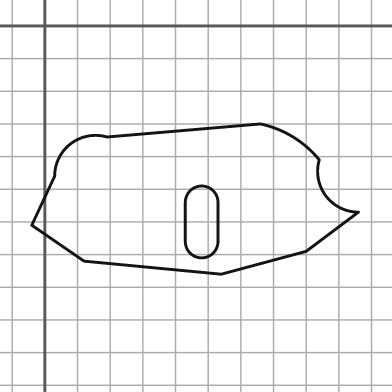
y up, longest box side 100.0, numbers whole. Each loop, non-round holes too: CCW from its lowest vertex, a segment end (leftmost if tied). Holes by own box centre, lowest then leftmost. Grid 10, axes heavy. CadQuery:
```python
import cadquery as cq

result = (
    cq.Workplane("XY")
    .moveTo(54.0, -76.0)
    .lineTo(80.0, -69.0)
    .lineTo(96.0, -57.0)
    .threePointArc((86.0, -52.0), (84.0, -41.0))
    .threePointArc((76.0, -34.0), (66.0, -30.0))
    .lineTo(19.0, -34.0)
    .threePointArc((8.0, -36.0), (3.0, -46.0))
    .lineTo(-4.0, -61.0)
    .lineTo(12.0, -72.0)
    .close()
    .moveTo(43.0, -66.0)
    .threePointArc((48.0, -71.0), (53.0, -66.0))
    .lineTo(53.0, -54.0)
    .threePointArc((48.0, -49.0), (43.0, -54.0))
    .close()
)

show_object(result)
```